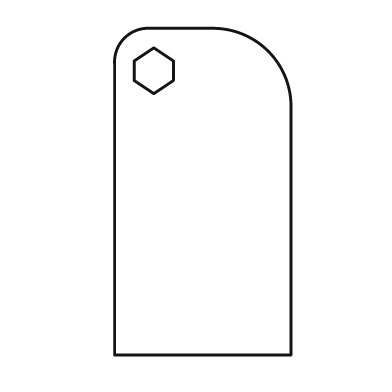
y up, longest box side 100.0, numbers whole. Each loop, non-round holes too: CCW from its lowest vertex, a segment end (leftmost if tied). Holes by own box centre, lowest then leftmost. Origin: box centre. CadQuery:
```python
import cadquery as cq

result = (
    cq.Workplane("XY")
    .moveTo(-27.0, -50.0)
    .lineTo(27.0, -50.0)
    .lineTo(27.0, 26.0)
    .threePointArc((20.0, 43.0), (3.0, 50.0))
    .lineTo(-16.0, 50.0)
    .threePointArc((-24.0, 47.0), (-27.0, 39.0))
    .close()
    .moveTo(-15.0, 30.0)
    .lineTo(-9.0, 34.0)
    .lineTo(-9.0, 40.0)
    .lineTo(-15.0, 44.0)
    .lineTo(-21.0, 40.0)
    .lineTo(-21.0, 34.0)
    .close()
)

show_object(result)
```